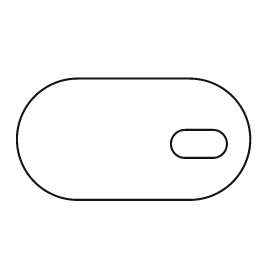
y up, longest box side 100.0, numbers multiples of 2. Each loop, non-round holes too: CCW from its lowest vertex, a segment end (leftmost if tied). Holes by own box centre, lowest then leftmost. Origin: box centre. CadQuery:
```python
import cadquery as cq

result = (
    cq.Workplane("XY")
    .moveTo(-24.0, -26.0)
    .lineTo(24.0, -26.0)
    .threePointArc((50.0, 0.0), (24.0, 26.0))
    .lineTo(-24.0, 26.0)
    .threePointArc((-50.0, 0.0), (-24.0, -26.0))
    .close()
    .moveTo(22.0, -8.0)
    .lineTo(34.0, -8.0)
    .threePointArc((40.0, -2.0), (34.0, 4.0))
    .lineTo(22.0, 4.0)
    .threePointArc((16.0, -2.0), (22.0, -8.0))
    .close()
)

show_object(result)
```